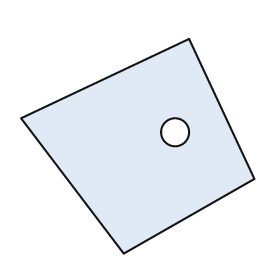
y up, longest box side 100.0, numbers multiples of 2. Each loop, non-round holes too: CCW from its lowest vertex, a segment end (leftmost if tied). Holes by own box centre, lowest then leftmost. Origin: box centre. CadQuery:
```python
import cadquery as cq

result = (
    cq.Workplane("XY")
    .moveTo(-6.0, -46.0)
    .lineTo(50.0, -14.0)
    .lineTo(22.0, 46.0)
    .lineTo(-50.0, 12.0)
    .close()
    .moveTo(16.0, 6.0)
    .circle(6.0)
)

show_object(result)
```